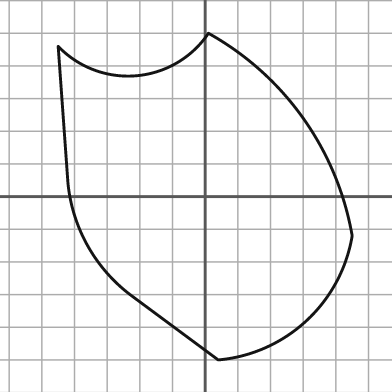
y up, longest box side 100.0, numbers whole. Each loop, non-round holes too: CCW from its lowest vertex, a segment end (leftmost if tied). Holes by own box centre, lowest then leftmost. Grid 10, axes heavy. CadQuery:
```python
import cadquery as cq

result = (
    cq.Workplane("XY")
    .moveTo(4.0, -50.0)
    .threePointArc((31.0, -38.0), (45.0, -12.0))
    .threePointArc((30.0, 24.0), (1.0, 50.0))
    .threePointArc((-21.0, 37.0), (-45.0, 46.0))
    .lineTo(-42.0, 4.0)
    .threePointArc((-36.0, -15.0), (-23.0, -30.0))
    .close()
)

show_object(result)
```